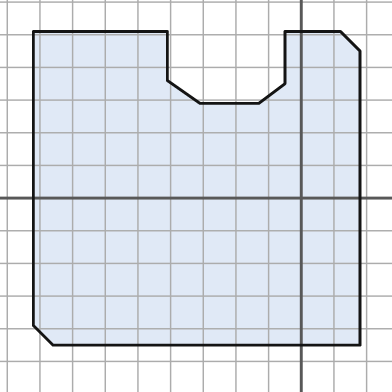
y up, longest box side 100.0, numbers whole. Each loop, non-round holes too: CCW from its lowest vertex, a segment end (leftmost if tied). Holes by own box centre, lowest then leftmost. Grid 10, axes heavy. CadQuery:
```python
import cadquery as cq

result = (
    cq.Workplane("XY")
    .moveTo(-76.0, -45.0)
    .lineTo(18.0, -45.0)
    .lineTo(18.0, 45.0)
    .lineTo(12.0, 51.0)
    .lineTo(-5.0, 51.0)
    .lineTo(-5.0, 35.0)
    .lineTo(-13.0, 29.0)
    .lineTo(-31.0, 29.0)
    .lineTo(-41.0, 36.0)
    .lineTo(-41.0, 51.0)
    .lineTo(-82.0, 51.0)
    .lineTo(-82.0, -39.0)
    .close()
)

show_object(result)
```